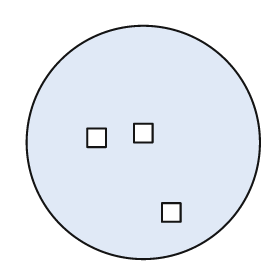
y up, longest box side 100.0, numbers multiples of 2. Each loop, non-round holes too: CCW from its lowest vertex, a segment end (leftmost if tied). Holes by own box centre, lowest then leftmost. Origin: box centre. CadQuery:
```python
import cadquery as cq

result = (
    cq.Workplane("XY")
    .moveTo(0.0, 0.0)
    .circle(50.0)
    .moveTo(8.0, -34.0)
    .lineTo(16.0, -34.0)
    .lineTo(16.0, -26.0)
    .lineTo(8.0, -26.0)
    .close()
    .moveTo(-24.0, -2.0)
    .lineTo(-16.0, -2.0)
    .lineTo(-16.0, 6.0)
    .lineTo(-24.0, 6.0)
    .close()
    .moveTo(-4.0, 0.0)
    .lineTo(4.0, 0.0)
    .lineTo(4.0, 8.0)
    .lineTo(-4.0, 8.0)
    .close()
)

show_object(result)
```